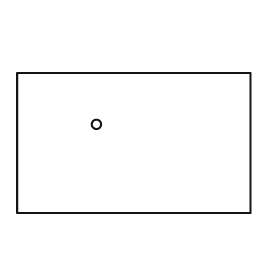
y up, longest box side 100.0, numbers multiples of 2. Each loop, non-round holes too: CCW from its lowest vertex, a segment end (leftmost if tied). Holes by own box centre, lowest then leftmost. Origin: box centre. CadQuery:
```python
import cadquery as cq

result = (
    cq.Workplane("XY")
    .moveTo(-50.0, -30.0)
    .lineTo(50.0, -30.0)
    .lineTo(50.0, 30.0)
    .lineTo(-50.0, 30.0)
    .close()
    .moveTo(-16.0, 8.0)
    .circle(2.0)
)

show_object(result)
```